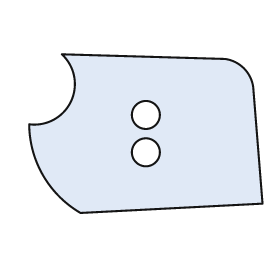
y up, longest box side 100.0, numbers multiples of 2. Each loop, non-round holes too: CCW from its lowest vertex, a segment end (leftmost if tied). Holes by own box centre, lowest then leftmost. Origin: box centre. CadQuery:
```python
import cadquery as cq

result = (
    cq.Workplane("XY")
    .moveTo(-28.0, -34.0)
    .lineTo(50.0, -30.0)
    .lineTo(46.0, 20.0)
    .threePointArc((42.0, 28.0), (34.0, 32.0))
    .lineTo(-36.0, 34.0)
    .threePointArc((-32.0, 14.0), (-50.0, 4.0))
    .threePointArc((-44.0, -18.0), (-28.0, -34.0))
    .close()
    .moveTo(0.0, -8.0)
    .circle(6.0)
    .moveTo(0.0, 8.0)
    .circle(6.0)
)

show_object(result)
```